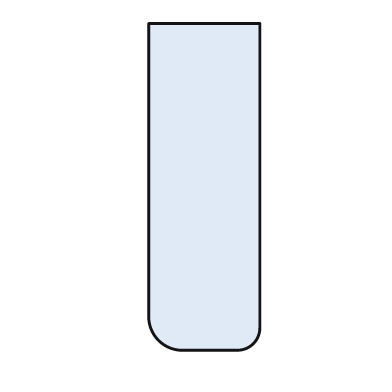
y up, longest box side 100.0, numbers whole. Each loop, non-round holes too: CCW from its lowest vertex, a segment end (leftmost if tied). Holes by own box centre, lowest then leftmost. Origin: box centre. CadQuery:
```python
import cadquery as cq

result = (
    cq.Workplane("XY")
    .moveTo(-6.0, -50.0)
    .lineTo(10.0, -50.0)
    .threePointArc((15.0, -48.0), (17.0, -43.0))
    .lineTo(17.0, 50.0)
    .lineTo(-17.0, 50.0)
    .lineTo(-17.0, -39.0)
    .threePointArc((-14.0, -47.0), (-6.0, -50.0))
    .close()
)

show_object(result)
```